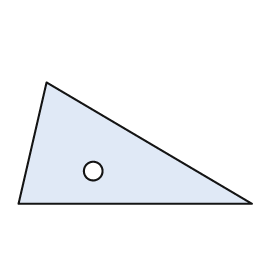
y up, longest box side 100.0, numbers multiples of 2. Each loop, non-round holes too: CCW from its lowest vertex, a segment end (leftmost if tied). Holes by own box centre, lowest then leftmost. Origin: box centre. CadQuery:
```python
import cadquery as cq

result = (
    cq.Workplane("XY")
    .moveTo(-50.0, -26.0)
    .lineTo(50.0, -26.0)
    .lineTo(-38.0, 26.0)
    .close()
    .moveTo(-18.0, -12.0)
    .circle(4.0)
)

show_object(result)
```